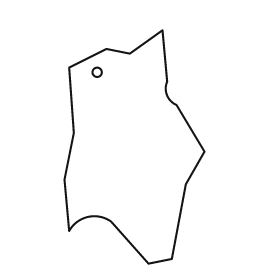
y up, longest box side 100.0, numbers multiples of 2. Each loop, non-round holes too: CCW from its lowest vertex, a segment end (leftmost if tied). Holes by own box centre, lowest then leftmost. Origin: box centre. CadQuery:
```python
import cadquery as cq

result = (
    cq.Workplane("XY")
    .moveTo(6.0, -50.0)
    .lineTo(16.0, -48.0)
    .lineTo(22.0, -16.0)
    .lineTo(30.0, -2.0)
    .lineTo(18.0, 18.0)
    .threePointArc((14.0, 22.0), (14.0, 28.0))
    .lineTo(12.0, 50.0)
    .lineTo(-2.0, 40.0)
    .lineTo(-12.0, 42.0)
    .lineTo(-28.0, 34.0)
    .lineTo(-26.0, 6.0)
    .lineTo(-30.0, -14.0)
    .lineTo(-28.0, -36.0)
    .threePointArc((-20.0, -30.0), (-10.0, -32.0))
    .close()
    .moveTo(-16.0, 32.0)
    .circle(2.0)
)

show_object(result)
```